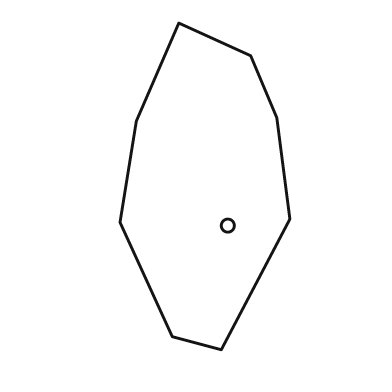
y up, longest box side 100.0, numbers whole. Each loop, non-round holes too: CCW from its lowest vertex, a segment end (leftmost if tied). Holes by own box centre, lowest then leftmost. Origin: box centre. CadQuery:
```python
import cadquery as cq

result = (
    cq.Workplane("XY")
    .moveTo(5.0, -50.0)
    .lineTo(26.0, -10.0)
    .lineTo(22.0, 21.0)
    .lineTo(14.0, 40.0)
    .lineTo(-8.0, 50.0)
    .lineTo(-21.0, 20.0)
    .lineTo(-26.0, -11.0)
    .lineTo(-10.0, -46.0)
    .close()
    .moveTo(7.0, -12.0)
    .circle(2.0)
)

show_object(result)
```